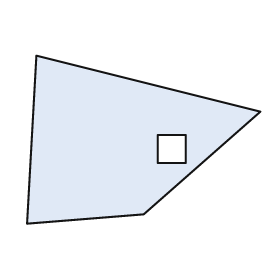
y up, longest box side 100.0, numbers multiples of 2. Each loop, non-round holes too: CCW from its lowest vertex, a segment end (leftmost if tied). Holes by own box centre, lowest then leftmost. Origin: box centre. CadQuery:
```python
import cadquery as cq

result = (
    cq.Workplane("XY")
    .moveTo(-50.0, -36.0)
    .lineTo(0.0, -32.0)
    .lineTo(50.0, 12.0)
    .lineTo(-46.0, 36.0)
    .close()
    .moveTo(6.0, -10.0)
    .lineTo(18.0, -10.0)
    .lineTo(18.0, 2.0)
    .lineTo(6.0, 2.0)
    .close()
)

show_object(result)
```